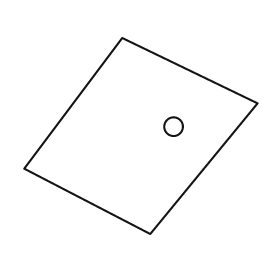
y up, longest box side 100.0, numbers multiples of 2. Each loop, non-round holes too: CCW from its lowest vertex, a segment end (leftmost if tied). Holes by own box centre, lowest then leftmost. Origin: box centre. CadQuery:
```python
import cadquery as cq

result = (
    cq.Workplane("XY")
    .moveTo(4.0, -42.0)
    .lineTo(50.0, 14.0)
    .lineTo(-8.0, 42.0)
    .lineTo(-50.0, -14.0)
    .close()
    .moveTo(14.0, 4.0)
    .circle(4.0)
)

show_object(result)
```